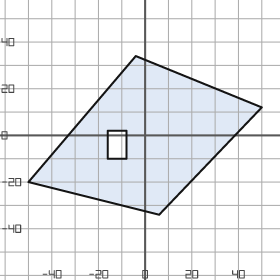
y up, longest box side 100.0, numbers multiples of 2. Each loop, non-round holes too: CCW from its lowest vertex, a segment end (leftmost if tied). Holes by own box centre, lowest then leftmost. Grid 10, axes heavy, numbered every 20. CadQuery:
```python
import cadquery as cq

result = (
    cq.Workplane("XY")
    .moveTo(6.0, -34.0)
    .lineTo(50.0, 12.0)
    .lineTo(-4.0, 34.0)
    .lineTo(-50.0, -20.0)
    .close()
    .moveTo(-16.0, -10.0)
    .lineTo(-8.0, -10.0)
    .lineTo(-8.0, 2.0)
    .lineTo(-16.0, 2.0)
    .close()
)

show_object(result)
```